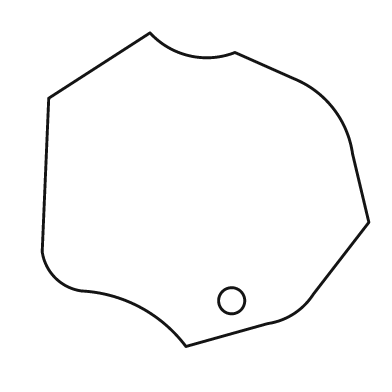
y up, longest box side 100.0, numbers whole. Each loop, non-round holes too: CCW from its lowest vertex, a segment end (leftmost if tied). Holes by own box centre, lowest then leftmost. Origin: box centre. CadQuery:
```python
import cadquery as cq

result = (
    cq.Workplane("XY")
    .moveTo(-6.0, -48.0)
    .lineTo(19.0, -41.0)
    .threePointArc((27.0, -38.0), (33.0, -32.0))
    .lineTo(50.0, -10.0)
    .lineTo(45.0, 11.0)
    .threePointArc((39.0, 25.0), (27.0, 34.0))
    .lineTo(9.0, 42.0)
    .threePointArc((-5.0, 41.0), (-17.0, 48.0))
    .lineTo(-48.0, 28.0)
    .lineTo(-50.0, -19.0)
    .threePointArc((-46.0, -27.0), (-38.0, -31.0))
    .threePointArc((-20.0, -36.0), (-6.0, -48.0))
    .close()
    .moveTo(8.0, -34.0)
    .circle(4.0)
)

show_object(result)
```